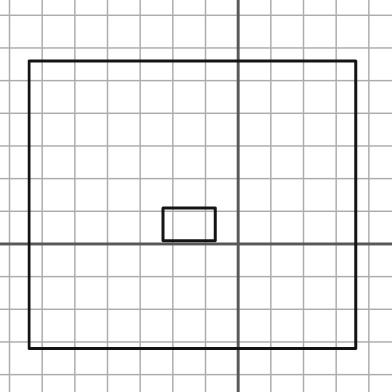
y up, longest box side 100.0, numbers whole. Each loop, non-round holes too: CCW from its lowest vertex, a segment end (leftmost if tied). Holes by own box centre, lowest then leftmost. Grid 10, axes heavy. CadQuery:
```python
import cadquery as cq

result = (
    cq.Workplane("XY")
    .moveTo(-64.0, -32.0)
    .lineTo(36.0, -32.0)
    .lineTo(36.0, 56.0)
    .lineTo(-64.0, 56.0)
    .close()
    .moveTo(-23.0, 1.0)
    .lineTo(-7.0, 1.0)
    .lineTo(-7.0, 11.0)
    .lineTo(-23.0, 11.0)
    .close()
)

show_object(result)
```